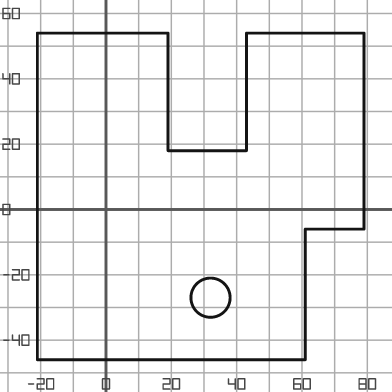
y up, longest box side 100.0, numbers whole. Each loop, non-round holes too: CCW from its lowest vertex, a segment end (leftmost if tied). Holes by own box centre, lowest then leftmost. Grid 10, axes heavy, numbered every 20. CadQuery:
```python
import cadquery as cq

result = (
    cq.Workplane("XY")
    .moveTo(-21.0, -46.0)
    .lineTo(61.0, -46.0)
    .lineTo(61.0, -6.0)
    .lineTo(79.0, -6.0)
    .lineTo(79.0, 54.0)
    .lineTo(43.0, 54.0)
    .lineTo(43.0, 18.0)
    .lineTo(19.0, 18.0)
    .lineTo(19.0, 54.0)
    .lineTo(-21.0, 54.0)
    .close()
    .moveTo(32.0, -27.0)
    .circle(6.0)
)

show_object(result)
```